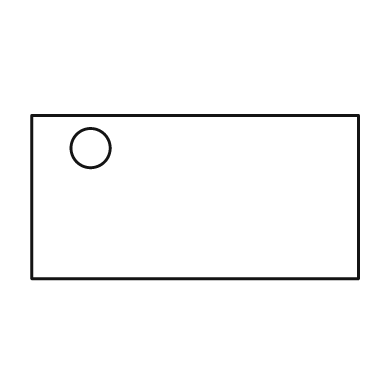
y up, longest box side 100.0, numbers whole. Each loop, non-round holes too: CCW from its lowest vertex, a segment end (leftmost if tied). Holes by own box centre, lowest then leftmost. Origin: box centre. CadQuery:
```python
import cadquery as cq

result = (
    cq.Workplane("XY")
    .moveTo(-50.0, -25.0)
    .lineTo(50.0, -25.0)
    .lineTo(50.0, 25.0)
    .lineTo(-50.0, 25.0)
    .close()
    .moveTo(-32.0, 15.0)
    .circle(6.0)
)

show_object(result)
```